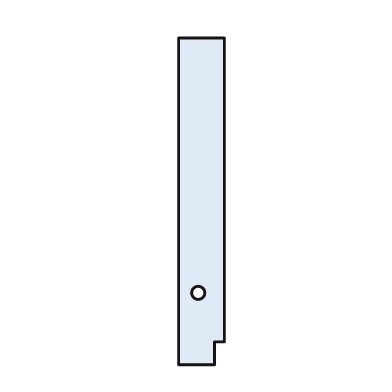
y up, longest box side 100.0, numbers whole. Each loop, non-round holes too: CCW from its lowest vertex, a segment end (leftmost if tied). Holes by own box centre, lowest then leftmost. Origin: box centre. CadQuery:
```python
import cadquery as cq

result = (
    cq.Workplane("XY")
    .moveTo(-7.0, -50.0)
    .lineTo(4.0, -50.0)
    .lineTo(4.0, -43.0)
    .lineTo(7.0, -43.0)
    .lineTo(7.0, 50.0)
    .lineTo(-7.0, 50.0)
    .close()
    .moveTo(-1.0, -28.0)
    .circle(2.0)
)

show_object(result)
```